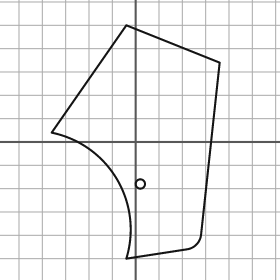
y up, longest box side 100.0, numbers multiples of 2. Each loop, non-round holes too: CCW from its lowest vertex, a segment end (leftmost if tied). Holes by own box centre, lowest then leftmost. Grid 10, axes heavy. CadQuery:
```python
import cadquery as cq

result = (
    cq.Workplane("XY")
    .moveTo(-4.0, -50.0)
    .lineTo(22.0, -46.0)
    .threePointArc((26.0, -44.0), (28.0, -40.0))
    .lineTo(36.0, 34.0)
    .lineTo(-4.0, 50.0)
    .lineTo(-36.0, 4.0)
    .threePointArc((-8.0, -16.0), (-4.0, -50.0))
    .close()
    .moveTo(2.0, -18.0)
    .circle(2.0)
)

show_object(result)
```